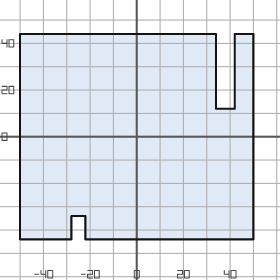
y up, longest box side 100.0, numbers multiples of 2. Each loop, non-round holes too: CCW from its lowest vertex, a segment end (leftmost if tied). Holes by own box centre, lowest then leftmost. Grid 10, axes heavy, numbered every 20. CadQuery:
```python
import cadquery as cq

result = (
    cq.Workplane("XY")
    .moveTo(-50.0, -44.0)
    .lineTo(-28.0, -44.0)
    .lineTo(-28.0, -34.0)
    .lineTo(-22.0, -34.0)
    .lineTo(-22.0, -44.0)
    .lineTo(50.0, -44.0)
    .lineTo(50.0, 44.0)
    .lineTo(42.0, 44.0)
    .lineTo(42.0, 12.0)
    .lineTo(34.0, 12.0)
    .lineTo(34.0, 44.0)
    .lineTo(-50.0, 44.0)
    .close()
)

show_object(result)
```